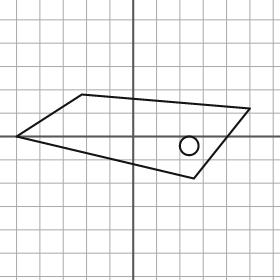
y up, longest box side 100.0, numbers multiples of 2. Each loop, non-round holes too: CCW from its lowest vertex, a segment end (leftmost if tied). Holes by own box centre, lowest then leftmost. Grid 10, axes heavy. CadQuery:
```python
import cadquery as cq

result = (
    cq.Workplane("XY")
    .moveTo(26.0, -18.0)
    .lineTo(50.0, 12.0)
    .lineTo(-22.0, 18.0)
    .lineTo(-50.0, 0.0)
    .close()
    .moveTo(24.0, -4.0)
    .circle(4.0)
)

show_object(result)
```